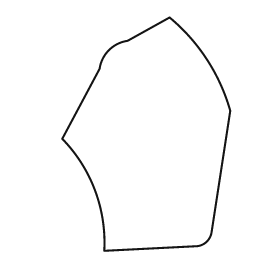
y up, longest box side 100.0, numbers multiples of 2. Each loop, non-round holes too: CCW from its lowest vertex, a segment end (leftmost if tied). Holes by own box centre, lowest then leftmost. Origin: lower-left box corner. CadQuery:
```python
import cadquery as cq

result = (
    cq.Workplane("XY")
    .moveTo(18.0, 0.0)
    .lineTo(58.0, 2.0)
    .threePointArc((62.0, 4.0), (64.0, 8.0))
    .lineTo(72.0, 60.0)
    .threePointArc((62.0, 82.0), (46.0, 100.0))
    .lineTo(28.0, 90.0)
    .threePointArc((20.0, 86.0), (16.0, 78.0))
    .lineTo(0.0, 48.0)
    .threePointArc((14.0, 26.0), (18.0, 0.0))
    .close()
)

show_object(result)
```